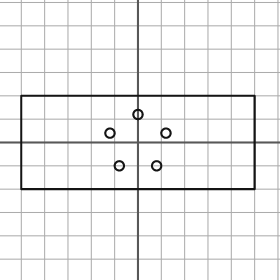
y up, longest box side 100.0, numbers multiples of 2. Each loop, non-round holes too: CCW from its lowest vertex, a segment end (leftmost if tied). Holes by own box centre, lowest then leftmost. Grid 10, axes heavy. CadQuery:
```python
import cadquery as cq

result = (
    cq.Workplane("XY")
    .moveTo(-50.0, -20.0)
    .lineTo(50.0, -20.0)
    .lineTo(50.0, 20.0)
    .lineTo(-50.0, 20.0)
    .close()
    .moveTo(-8.0, -10.0)
    .circle(2.0)
    .moveTo(8.0, -10.0)
    .circle(2.0)
    .moveTo(-12.0, 4.0)
    .circle(2.0)
    .moveTo(12.0, 4.0)
    .circle(2.0)
    .moveTo(0.0, 12.0)
    .circle(2.0)
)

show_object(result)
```